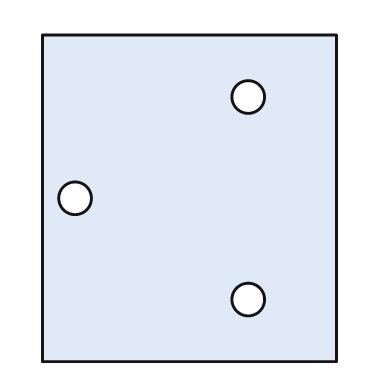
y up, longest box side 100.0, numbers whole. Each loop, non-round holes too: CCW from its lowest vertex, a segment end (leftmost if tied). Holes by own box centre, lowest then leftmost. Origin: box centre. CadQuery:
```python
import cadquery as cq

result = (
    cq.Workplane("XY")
    .moveTo(-45.0, -50.0)
    .lineTo(45.0, -50.0)
    .lineTo(45.0, 50.0)
    .lineTo(-45.0, 50.0)
    .close()
    .moveTo(18.0, -31.0)
    .circle(5.0)
    .moveTo(-35.0, 0.0)
    .circle(5.0)
    .moveTo(18.0, 31.0)
    .circle(5.0)
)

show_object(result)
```